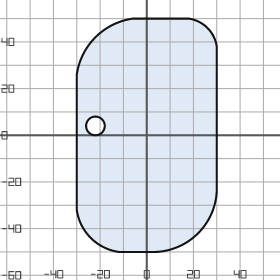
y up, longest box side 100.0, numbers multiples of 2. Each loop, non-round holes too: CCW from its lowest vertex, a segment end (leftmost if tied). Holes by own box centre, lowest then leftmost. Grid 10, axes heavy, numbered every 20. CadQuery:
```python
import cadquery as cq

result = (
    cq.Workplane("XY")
    .moveTo(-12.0, -50.0)
    .lineTo(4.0, -50.0)
    .threePointArc((22.0, -42.0), (30.0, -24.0))
    .lineTo(30.0, 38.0)
    .threePointArc((26.0, 46.0), (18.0, 50.0))
    .lineTo(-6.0, 50.0)
    .threePointArc((-22.0, 42.0), (-30.0, 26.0))
    .lineTo(-30.0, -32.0)
    .threePointArc((-24.0, -44.0), (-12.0, -50.0))
    .close()
    .moveTo(-22.0, 4.0)
    .circle(4.0)
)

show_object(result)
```